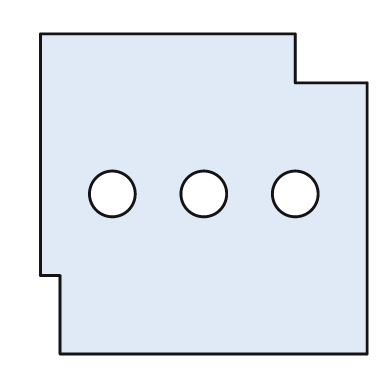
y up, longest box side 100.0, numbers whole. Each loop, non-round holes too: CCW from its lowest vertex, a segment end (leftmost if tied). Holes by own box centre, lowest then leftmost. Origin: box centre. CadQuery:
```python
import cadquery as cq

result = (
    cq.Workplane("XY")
    .moveTo(-44.0, -49.0)
    .lineTo(50.0, -49.0)
    .lineTo(50.0, 34.0)
    .lineTo(28.0, 34.0)
    .lineTo(28.0, 49.0)
    .lineTo(-50.0, 49.0)
    .lineTo(-50.0, -25.0)
    .lineTo(-44.0, -25.0)
    .close()
    .moveTo(-28.0, 0.0)
    .circle(7.0)
    .moveTo(0.0, 0.0)
    .circle(7.0)
    .moveTo(28.0, 0.0)
    .circle(7.0)
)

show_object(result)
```